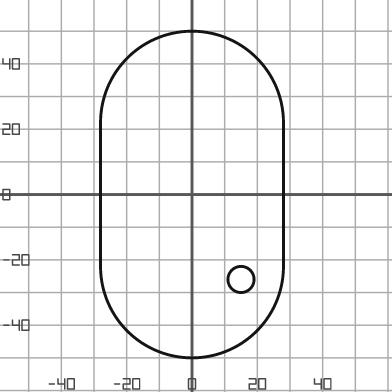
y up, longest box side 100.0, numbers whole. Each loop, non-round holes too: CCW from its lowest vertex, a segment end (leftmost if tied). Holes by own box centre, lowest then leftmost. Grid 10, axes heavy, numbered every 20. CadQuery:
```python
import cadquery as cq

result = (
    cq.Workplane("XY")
    .moveTo(-28.0, -22.0)
    .threePointArc((0.0, -50.0), (28.0, -22.0))
    .lineTo(28.0, 22.0)
    .threePointArc((0.0, 50.0), (-28.0, 22.0))
    .close()
    .moveTo(15.0, -26.0)
    .circle(4.0)
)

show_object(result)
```